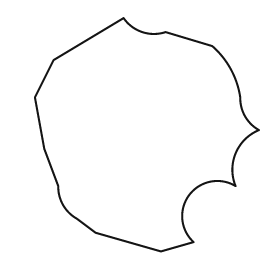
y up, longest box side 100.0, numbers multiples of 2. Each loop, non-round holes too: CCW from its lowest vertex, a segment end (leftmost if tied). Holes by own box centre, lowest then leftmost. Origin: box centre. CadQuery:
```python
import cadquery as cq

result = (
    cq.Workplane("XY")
    .moveTo(6.0, -50.0)
    .lineTo(20.0, -46.0)
    .threePointArc((18.0, -26.0), (38.0, -22.0))
    .threePointArc((38.0, -8.0), (48.0, 2.0))
    .threePointArc((42.0, 8.0), (40.0, 16.0))
    .threePointArc((36.0, 28.0), (28.0, 38.0))
    .lineTo(8.0, 44.0)
    .threePointArc((-2.0, 44.0), (-10.0, 50.0))
    .lineTo(-40.0, 32.0)
    .lineTo(-48.0, 16.0)
    .lineTo(-44.0, -6.0)
    .lineTo(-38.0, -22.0)
    .threePointArc((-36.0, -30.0), (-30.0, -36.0))
    .lineTo(-22.0, -42.0)
    .close()
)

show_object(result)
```